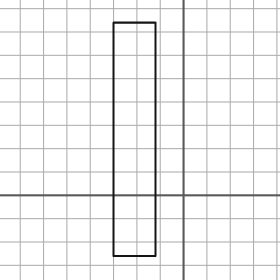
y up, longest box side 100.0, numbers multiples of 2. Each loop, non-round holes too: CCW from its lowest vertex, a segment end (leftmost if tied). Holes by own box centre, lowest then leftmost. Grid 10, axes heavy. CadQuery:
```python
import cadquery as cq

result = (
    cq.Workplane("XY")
    .moveTo(-30.0, -26.0)
    .lineTo(-12.0, -26.0)
    .lineTo(-12.0, 74.0)
    .lineTo(-30.0, 74.0)
    .close()
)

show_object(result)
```